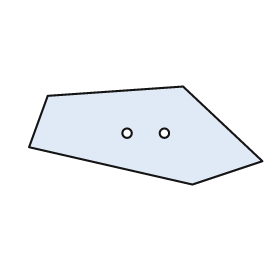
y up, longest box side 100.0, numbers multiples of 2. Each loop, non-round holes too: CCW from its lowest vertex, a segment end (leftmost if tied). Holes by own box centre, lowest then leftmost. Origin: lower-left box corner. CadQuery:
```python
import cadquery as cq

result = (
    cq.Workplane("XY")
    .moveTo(70.0, 0.0)
    .lineTo(100.0, 10.0)
    .lineTo(66.0, 42.0)
    .lineTo(8.0, 38.0)
    .lineTo(0.0, 16.0)
    .close()
    .moveTo(42.0, 22.0)
    .circle(2.0)
    .moveTo(58.0, 22.0)
    .circle(2.0)
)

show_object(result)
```